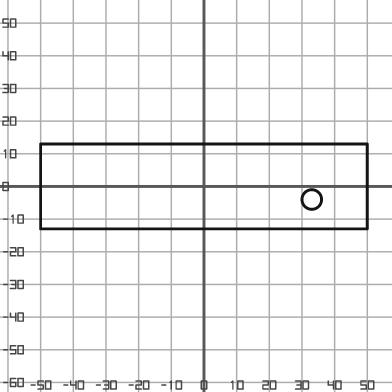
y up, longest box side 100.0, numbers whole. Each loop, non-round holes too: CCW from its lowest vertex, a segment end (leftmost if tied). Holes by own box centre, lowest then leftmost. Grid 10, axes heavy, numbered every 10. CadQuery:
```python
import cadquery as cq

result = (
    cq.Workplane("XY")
    .moveTo(-50.0, -13.0)
    .lineTo(50.0, -13.0)
    .lineTo(50.0, 13.0)
    .lineTo(-50.0, 13.0)
    .close()
    .moveTo(33.0, -4.0)
    .circle(3.0)
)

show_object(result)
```